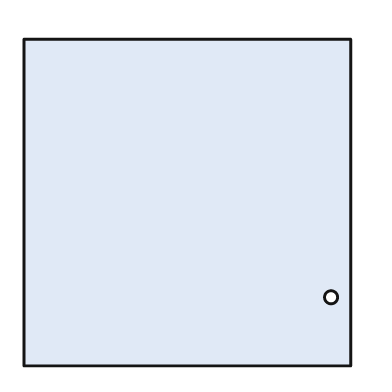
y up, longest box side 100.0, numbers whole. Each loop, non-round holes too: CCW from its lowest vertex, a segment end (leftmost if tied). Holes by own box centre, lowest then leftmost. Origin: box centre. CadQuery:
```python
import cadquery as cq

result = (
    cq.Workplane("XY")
    .moveTo(-50.0, -50.0)
    .lineTo(50.0, -50.0)
    .lineTo(50.0, 50.0)
    .lineTo(-50.0, 50.0)
    .close()
    .moveTo(44.0, -29.0)
    .circle(2.0)
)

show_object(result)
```